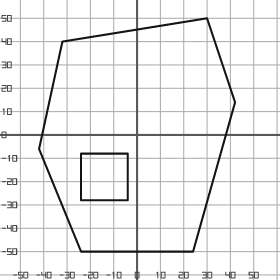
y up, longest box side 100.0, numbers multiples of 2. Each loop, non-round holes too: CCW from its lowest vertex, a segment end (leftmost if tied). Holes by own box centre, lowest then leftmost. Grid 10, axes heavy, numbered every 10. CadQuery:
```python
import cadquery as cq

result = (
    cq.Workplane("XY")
    .moveTo(-24.0, -50.0)
    .lineTo(24.0, -50.0)
    .lineTo(42.0, 14.0)
    .lineTo(30.0, 50.0)
    .lineTo(-32.0, 40.0)
    .lineTo(-42.0, -6.0)
    .close()
    .moveTo(-24.0, -28.0)
    .lineTo(-4.0, -28.0)
    .lineTo(-4.0, -8.0)
    .lineTo(-24.0, -8.0)
    .close()
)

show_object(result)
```